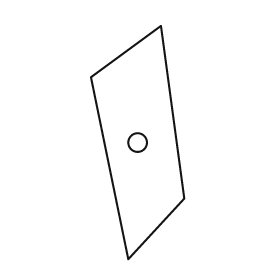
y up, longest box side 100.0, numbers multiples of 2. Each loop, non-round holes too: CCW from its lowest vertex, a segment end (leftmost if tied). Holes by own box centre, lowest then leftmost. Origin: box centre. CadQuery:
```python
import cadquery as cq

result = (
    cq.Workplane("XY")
    .moveTo(-4.0, -50.0)
    .lineTo(20.0, -24.0)
    .lineTo(10.0, 50.0)
    .lineTo(-20.0, 28.0)
    .close()
    .moveTo(0.0, 0.0)
    .circle(4.0)
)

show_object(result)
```